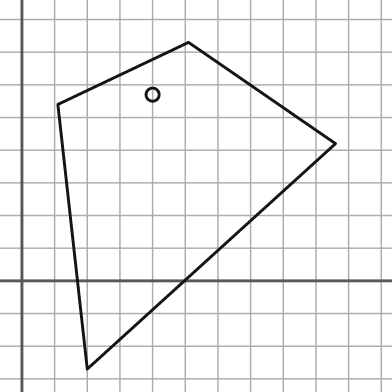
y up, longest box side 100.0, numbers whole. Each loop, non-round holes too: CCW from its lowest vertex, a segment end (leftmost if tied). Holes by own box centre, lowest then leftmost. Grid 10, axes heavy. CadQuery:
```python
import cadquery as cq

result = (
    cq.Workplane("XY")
    .moveTo(20.0, -27.0)
    .lineTo(96.0, 42.0)
    .lineTo(51.0, 73.0)
    .lineTo(11.0, 54.0)
    .close()
    .moveTo(40.0, 57.0)
    .circle(2.0)
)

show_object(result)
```